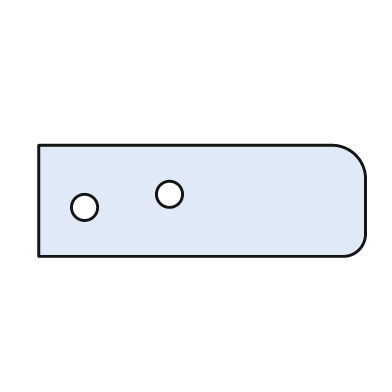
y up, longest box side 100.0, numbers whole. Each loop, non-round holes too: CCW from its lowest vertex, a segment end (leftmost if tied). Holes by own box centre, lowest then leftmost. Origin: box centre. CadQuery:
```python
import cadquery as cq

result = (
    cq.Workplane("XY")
    .moveTo(-50.0, -17.0)
    .lineTo(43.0, -17.0)
    .threePointArc((48.0, -15.0), (50.0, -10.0))
    .lineTo(50.0, 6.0)
    .threePointArc((47.0, 14.0), (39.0, 17.0))
    .lineTo(-50.0, 17.0)
    .close()
    .moveTo(-36.0, -2.0)
    .circle(4.0)
    .moveTo(-10.0, 2.0)
    .circle(4.0)
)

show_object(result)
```